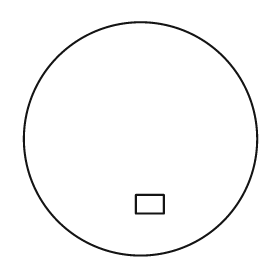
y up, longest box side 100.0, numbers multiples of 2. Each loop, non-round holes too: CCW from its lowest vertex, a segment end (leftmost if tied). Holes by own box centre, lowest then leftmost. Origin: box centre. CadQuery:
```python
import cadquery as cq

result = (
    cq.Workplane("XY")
    .moveTo(0.0, 0.0)
    .circle(50.0)
    .moveTo(-2.0, -32.0)
    .lineTo(10.0, -32.0)
    .lineTo(10.0, -24.0)
    .lineTo(-2.0, -24.0)
    .close()
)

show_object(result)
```